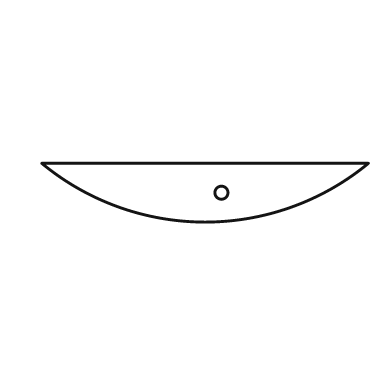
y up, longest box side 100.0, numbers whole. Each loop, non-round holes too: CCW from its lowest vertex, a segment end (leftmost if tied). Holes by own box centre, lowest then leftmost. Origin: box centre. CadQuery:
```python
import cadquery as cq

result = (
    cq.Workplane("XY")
    .moveTo(-50.0, 9.0)
    .threePointArc((0.0, -9.0), (50.0, 9.0))
    .close()
    .moveTo(5.0, 0.0)
    .circle(2.0)
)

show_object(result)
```